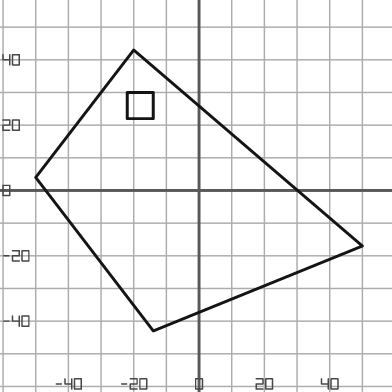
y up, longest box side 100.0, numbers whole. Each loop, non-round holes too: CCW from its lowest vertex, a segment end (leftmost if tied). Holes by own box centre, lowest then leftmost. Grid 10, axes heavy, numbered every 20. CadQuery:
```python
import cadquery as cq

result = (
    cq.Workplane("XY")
    .moveTo(-14.0, -43.0)
    .lineTo(50.0, -17.0)
    .lineTo(-20.0, 43.0)
    .lineTo(-50.0, 4.0)
    .close()
    .moveTo(-22.0, 22.0)
    .lineTo(-14.0, 22.0)
    .lineTo(-14.0, 30.0)
    .lineTo(-22.0, 30.0)
    .close()
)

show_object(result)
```